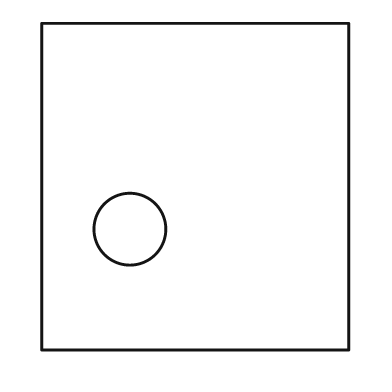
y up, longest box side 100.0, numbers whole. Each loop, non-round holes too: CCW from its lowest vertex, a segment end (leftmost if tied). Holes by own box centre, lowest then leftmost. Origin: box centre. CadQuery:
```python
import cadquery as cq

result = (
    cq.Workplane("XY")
    .moveTo(-47.0, -50.0)
    .lineTo(47.0, -50.0)
    .lineTo(47.0, 50.0)
    .lineTo(-47.0, 50.0)
    .close()
    .moveTo(-20.0, -13.0)
    .circle(11.0)
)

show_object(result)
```